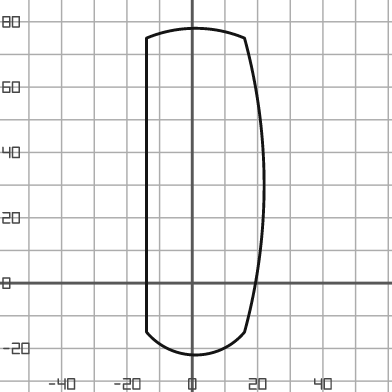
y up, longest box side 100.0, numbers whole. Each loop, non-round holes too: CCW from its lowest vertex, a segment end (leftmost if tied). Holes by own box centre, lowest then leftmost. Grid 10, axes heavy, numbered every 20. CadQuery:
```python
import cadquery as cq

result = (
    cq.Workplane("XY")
    .moveTo(-14.0, -15.0)
    .threePointArc((1.0, -22.0), (16.0, -15.0))
    .threePointArc((22.0, 30.0), (16.0, 75.0))
    .threePointArc((1.0, 78.0), (-14.0, 75.0))
    .close()
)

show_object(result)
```